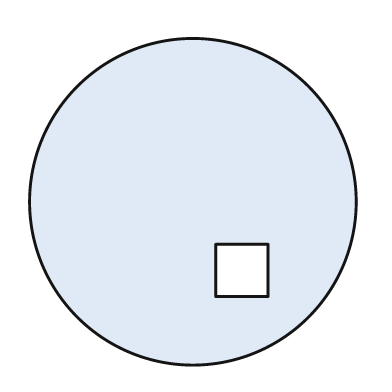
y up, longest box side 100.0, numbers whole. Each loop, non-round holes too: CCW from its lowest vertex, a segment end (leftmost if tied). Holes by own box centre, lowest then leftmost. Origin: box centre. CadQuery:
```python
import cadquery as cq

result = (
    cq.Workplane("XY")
    .moveTo(0.0, 0.0)
    .circle(50.0)
    .moveTo(7.0, -29.0)
    .lineTo(23.0, -29.0)
    .lineTo(23.0, -13.0)
    .lineTo(7.0, -13.0)
    .close()
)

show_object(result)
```